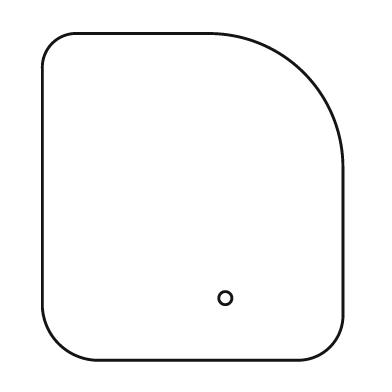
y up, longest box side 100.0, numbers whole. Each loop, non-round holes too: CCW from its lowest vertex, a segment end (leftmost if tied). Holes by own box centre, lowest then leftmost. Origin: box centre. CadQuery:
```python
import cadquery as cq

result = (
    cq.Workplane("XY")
    .moveTo(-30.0, -50.0)
    .lineTo(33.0, -50.0)
    .threePointArc((42.0, -46.0), (46.0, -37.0))
    .lineTo(46.0, 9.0)
    .threePointArc((34.0, 38.0), (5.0, 50.0))
    .lineTo(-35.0, 50.0)
    .threePointArc((-43.0, 47.0), (-46.0, 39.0))
    .lineTo(-46.0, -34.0)
    .threePointArc((-41.0, -45.0), (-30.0, -50.0))
    .close()
    .moveTo(10.0, -31.0)
    .circle(2.0)
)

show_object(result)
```